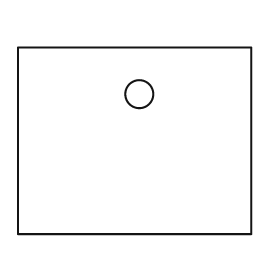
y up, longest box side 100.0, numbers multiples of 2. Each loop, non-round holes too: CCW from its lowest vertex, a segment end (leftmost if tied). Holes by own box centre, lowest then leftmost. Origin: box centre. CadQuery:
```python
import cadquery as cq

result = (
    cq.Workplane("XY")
    .moveTo(-50.0, -40.0)
    .lineTo(50.0, -40.0)
    .lineTo(50.0, 40.0)
    .lineTo(-50.0, 40.0)
    .close()
    .moveTo(2.0, 20.0)
    .circle(6.0)
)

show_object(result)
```